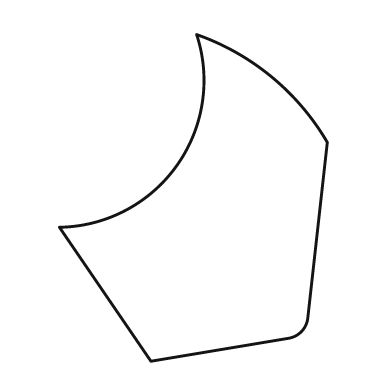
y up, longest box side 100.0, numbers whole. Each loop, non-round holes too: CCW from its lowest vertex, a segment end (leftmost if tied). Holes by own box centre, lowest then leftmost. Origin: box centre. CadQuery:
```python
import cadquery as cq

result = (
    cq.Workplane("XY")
    .moveTo(-13.0, -50.0)
    .lineTo(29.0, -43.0)
    .threePointArc((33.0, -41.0), (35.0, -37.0))
    .lineTo(41.0, 17.0)
    .threePointArc((24.0, 37.0), (1.0, 50.0))
    .threePointArc((-5.0, 10.0), (-41.0, -9.0))
    .close()
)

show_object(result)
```